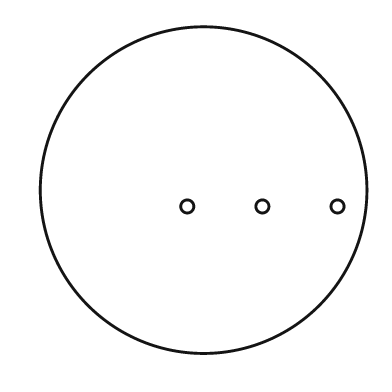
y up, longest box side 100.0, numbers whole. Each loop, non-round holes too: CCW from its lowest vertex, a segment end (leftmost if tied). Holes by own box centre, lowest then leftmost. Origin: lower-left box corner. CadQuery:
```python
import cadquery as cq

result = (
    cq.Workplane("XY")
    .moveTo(50.0, 50.0)
    .circle(50.0)
    .moveTo(45.0, 45.0)
    .circle(2.0)
    .moveTo(68.0, 45.0)
    .circle(2.0)
    .moveTo(91.0, 45.0)
    .circle(2.0)
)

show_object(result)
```